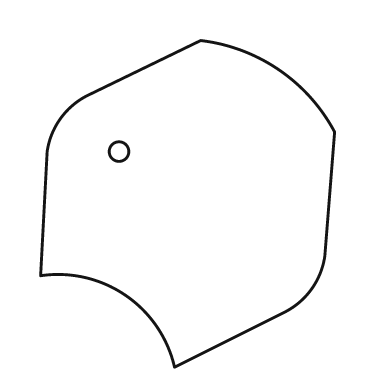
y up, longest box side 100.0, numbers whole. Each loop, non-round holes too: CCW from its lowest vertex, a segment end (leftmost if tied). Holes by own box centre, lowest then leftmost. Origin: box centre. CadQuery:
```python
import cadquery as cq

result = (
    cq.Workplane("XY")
    .moveTo(-4.0, -50.0)
    .lineTo(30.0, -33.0)
    .threePointArc((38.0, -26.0), (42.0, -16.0))
    .lineTo(45.0, 22.0)
    .threePointArc((28.0, 41.0), (4.0, 50.0))
    .lineTo(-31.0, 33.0)
    .threePointArc((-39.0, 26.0), (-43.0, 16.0))
    .lineTo(-45.0, -22.0)
    .threePointArc((-19.0, -28.0), (-4.0, -50.0))
    .close()
    .moveTo(-21.0, 16.0)
    .circle(3.0)
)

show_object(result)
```